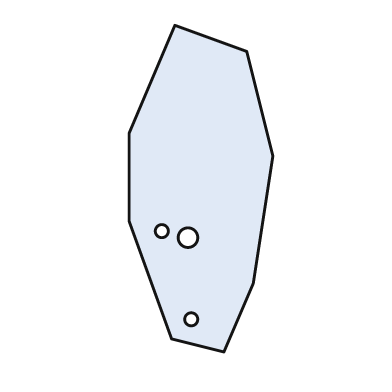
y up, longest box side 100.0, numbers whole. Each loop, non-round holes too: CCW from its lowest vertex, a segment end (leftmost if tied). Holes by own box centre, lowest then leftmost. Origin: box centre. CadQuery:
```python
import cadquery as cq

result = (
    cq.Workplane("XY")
    .moveTo(7.0, -50.0)
    .lineTo(16.0, -29.0)
    .lineTo(22.0, 10.0)
    .lineTo(14.0, 42.0)
    .lineTo(-8.0, 50.0)
    .lineTo(-22.0, 17.0)
    .lineTo(-22.0, -10.0)
    .lineTo(-9.0, -46.0)
    .close()
    .moveTo(-3.0, -40.0)
    .circle(2.0)
    .moveTo(-4.0, -15.0)
    .circle(3.0)
    .moveTo(-12.0, -13.0)
    .circle(2.0)
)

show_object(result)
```